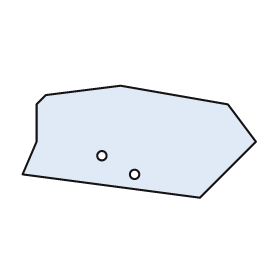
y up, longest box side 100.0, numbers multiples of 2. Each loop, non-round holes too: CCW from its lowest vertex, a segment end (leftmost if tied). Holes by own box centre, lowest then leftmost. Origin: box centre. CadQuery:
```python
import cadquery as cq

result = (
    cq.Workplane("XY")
    .moveTo(26.0, -24.0)
    .lineTo(50.0, 0.0)
    .lineTo(38.0, 16.0)
    .lineTo(-8.0, 24.0)
    .lineTo(-40.0, 20.0)
    .lineTo(-44.0, 16.0)
    .lineTo(-44.0, 0.0)
    .lineTo(-50.0, -14.0)
    .close()
    .moveTo(-2.0, -14.0)
    .circle(2.0)
    .moveTo(-16.0, -6.0)
    .circle(2.0)
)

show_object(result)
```